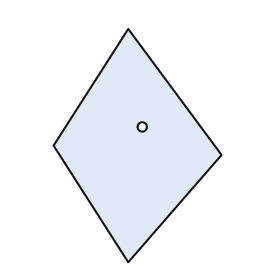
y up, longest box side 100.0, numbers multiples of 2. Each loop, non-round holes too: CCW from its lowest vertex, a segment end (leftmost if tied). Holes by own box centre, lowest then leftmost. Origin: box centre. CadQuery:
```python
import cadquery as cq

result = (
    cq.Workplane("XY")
    .moveTo(-4.0, -50.0)
    .lineTo(36.0, -4.0)
    .lineTo(-4.0, 50.0)
    .lineTo(-36.0, 0.0)
    .close()
    .moveTo(2.0, 8.0)
    .circle(2.0)
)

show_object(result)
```